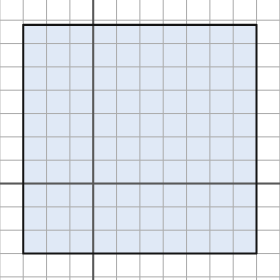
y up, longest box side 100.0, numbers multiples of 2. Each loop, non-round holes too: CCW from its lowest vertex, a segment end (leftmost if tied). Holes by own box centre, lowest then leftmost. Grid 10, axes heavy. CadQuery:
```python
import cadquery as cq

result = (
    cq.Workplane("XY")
    .moveTo(-30.0, -30.0)
    .lineTo(70.0, -30.0)
    .lineTo(70.0, 68.0)
    .lineTo(-30.0, 68.0)
    .close()
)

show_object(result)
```